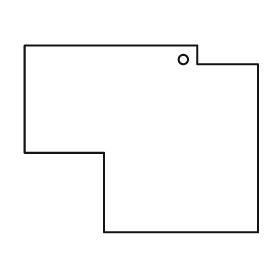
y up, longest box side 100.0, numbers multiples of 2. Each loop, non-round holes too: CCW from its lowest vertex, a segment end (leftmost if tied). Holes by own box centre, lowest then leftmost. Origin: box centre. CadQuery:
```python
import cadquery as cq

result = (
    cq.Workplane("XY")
    .moveTo(-16.0, -40.0)
    .lineTo(50.0, -40.0)
    .lineTo(50.0, 32.0)
    .lineTo(24.0, 32.0)
    .lineTo(24.0, 40.0)
    .lineTo(-50.0, 40.0)
    .lineTo(-50.0, -6.0)
    .lineTo(-16.0, -6.0)
    .close()
    .moveTo(18.0, 34.0)
    .circle(2.0)
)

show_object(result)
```